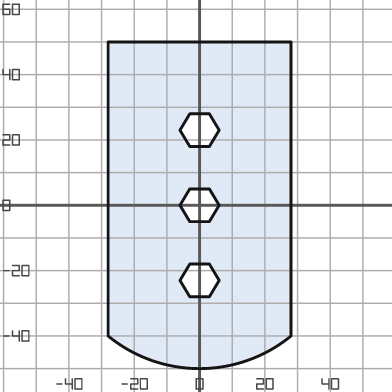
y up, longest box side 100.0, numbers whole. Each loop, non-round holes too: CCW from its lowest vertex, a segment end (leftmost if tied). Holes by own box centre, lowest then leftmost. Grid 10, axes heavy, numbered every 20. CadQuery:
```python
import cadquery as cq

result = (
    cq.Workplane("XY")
    .moveTo(-28.0, -40.0)
    .threePointArc((0.0, -50.0), (28.0, -40.0))
    .lineTo(28.0, 50.0)
    .lineTo(-28.0, 50.0)
    .close()
    .moveTo(-3.0, -28.0)
    .lineTo(3.0, -28.0)
    .lineTo(6.0, -23.0)
    .lineTo(3.0, -18.0)
    .lineTo(-3.0, -18.0)
    .lineTo(-6.0, -23.0)
    .close()
    .moveTo(-3.0, -5.0)
    .lineTo(3.0, -5.0)
    .lineTo(6.0, 0.0)
    .lineTo(3.0, 5.0)
    .lineTo(-3.0, 5.0)
    .lineTo(-6.0, 0.0)
    .close()
    .moveTo(-3.0, 18.0)
    .lineTo(3.0, 18.0)
    .lineTo(6.0, 23.0)
    .lineTo(3.0, 28.0)
    .lineTo(-3.0, 28.0)
    .lineTo(-6.0, 23.0)
    .close()
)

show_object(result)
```